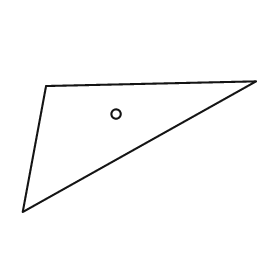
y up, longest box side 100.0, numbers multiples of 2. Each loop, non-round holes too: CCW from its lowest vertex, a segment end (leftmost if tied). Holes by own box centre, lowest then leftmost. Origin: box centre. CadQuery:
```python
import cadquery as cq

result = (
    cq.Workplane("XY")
    .moveTo(-50.0, -28.0)
    .lineTo(50.0, 28.0)
    .lineTo(-40.0, 26.0)
    .close()
    .moveTo(-10.0, 14.0)
    .circle(2.0)
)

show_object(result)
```